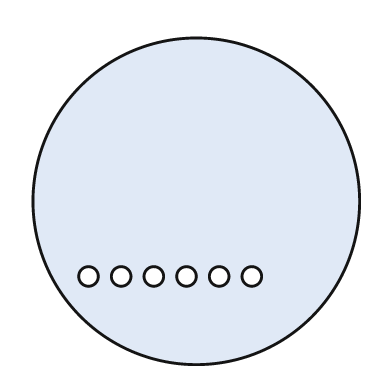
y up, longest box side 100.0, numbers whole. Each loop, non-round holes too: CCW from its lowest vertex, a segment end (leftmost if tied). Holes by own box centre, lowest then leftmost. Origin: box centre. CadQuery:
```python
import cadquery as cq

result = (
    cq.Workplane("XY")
    .moveTo(0.0, 0.0)
    .circle(50.0)
    .moveTo(-33.0, -23.0)
    .circle(3.0)
    .moveTo(-23.0, -23.0)
    .circle(3.0)
    .moveTo(-13.0, -23.0)
    .circle(3.0)
    .moveTo(-3.0, -23.0)
    .circle(3.0)
    .moveTo(7.0, -23.0)
    .circle(3.0)
    .moveTo(17.0, -23.0)
    .circle(3.0)
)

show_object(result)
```